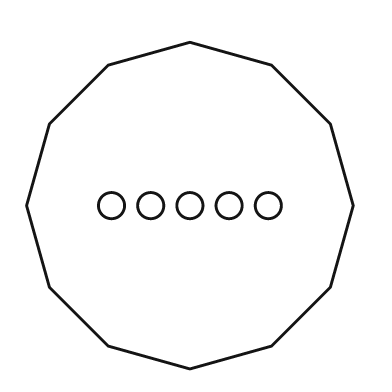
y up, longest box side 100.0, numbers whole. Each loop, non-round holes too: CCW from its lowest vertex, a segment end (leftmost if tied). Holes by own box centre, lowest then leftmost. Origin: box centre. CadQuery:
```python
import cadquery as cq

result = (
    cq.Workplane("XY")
    .moveTo(0.0, -50.0)
    .lineTo(25.0, -43.0)
    .lineTo(43.0, -25.0)
    .lineTo(50.0, 0.0)
    .lineTo(43.0, 25.0)
    .lineTo(25.0, 43.0)
    .lineTo(0.0, 50.0)
    .lineTo(-25.0, 43.0)
    .lineTo(-43.0, 25.0)
    .lineTo(-50.0, 0.0)
    .lineTo(-43.0, -25.0)
    .lineTo(-25.0, -43.0)
    .close()
    .moveTo(-24.0, 0.0)
    .circle(4.0)
    .moveTo(-12.0, 0.0)
    .circle(4.0)
    .moveTo(0.0, 0.0)
    .circle(4.0)
    .moveTo(12.0, 0.0)
    .circle(4.0)
    .moveTo(24.0, 0.0)
    .circle(4.0)
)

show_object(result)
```